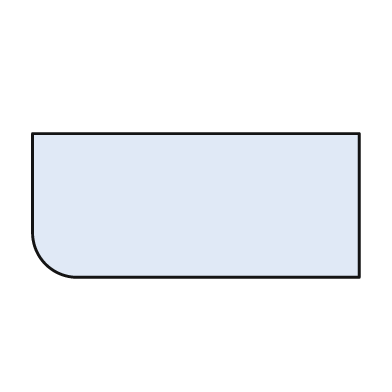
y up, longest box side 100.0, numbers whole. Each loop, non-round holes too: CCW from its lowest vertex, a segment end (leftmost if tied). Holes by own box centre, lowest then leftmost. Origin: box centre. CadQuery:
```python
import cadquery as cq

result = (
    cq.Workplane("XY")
    .moveTo(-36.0, -22.0)
    .lineTo(50.0, -22.0)
    .lineTo(50.0, 22.0)
    .lineTo(-50.0, 22.0)
    .lineTo(-50.0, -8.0)
    .threePointArc((-46.0, -18.0), (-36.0, -22.0))
    .close()
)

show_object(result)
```